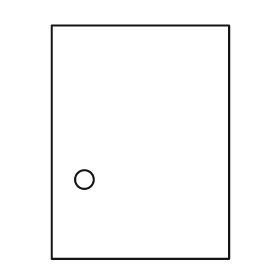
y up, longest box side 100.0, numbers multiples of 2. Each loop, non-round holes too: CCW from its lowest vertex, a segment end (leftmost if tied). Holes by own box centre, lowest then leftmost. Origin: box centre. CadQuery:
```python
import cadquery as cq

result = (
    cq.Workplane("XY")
    .moveTo(-38.0, -50.0)
    .lineTo(38.0, -50.0)
    .lineTo(38.0, 50.0)
    .lineTo(-38.0, 50.0)
    .close()
    .moveTo(-24.0, -16.0)
    .circle(4.0)
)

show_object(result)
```